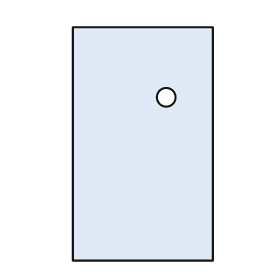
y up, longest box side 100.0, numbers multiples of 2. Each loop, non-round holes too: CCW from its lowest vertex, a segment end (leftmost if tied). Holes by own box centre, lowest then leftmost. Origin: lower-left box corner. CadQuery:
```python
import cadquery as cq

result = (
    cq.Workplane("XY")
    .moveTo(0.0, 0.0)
    .lineTo(60.0, 0.0)
    .lineTo(60.0, 100.0)
    .lineTo(0.0, 100.0)
    .close()
    .moveTo(40.0, 70.0)
    .circle(4.0)
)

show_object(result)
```